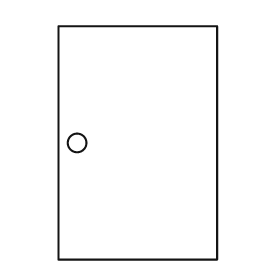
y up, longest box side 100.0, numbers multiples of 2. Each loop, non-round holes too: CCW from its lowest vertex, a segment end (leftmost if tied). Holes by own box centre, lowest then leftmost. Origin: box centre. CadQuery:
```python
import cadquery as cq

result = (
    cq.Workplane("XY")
    .moveTo(-34.0, -50.0)
    .lineTo(34.0, -50.0)
    .lineTo(34.0, 50.0)
    .lineTo(-34.0, 50.0)
    .close()
    .moveTo(-26.0, 0.0)
    .circle(4.0)
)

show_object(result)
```